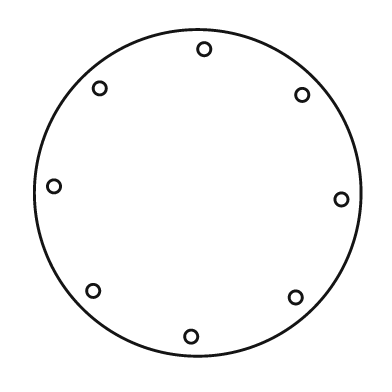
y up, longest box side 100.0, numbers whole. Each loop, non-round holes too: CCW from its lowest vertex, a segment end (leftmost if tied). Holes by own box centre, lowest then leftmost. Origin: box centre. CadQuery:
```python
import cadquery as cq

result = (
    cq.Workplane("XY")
    .moveTo(0.0, 0.0)
    .circle(50.0)
    .moveTo(-2.0, -44.0)
    .circle(2.0)
    .moveTo(30.0, -32.0)
    .circle(2.0)
    .moveTo(-32.0, -30.0)
    .circle(2.0)
    .moveTo(44.0, -2.0)
    .circle(2.0)
    .moveTo(-44.0, 2.0)
    .circle(2.0)
    .moveTo(32.0, 30.0)
    .circle(2.0)
    .moveTo(-30.0, 32.0)
    .circle(2.0)
    .moveTo(2.0, 44.0)
    .circle(2.0)
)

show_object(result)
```